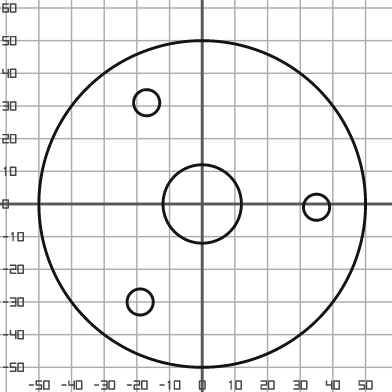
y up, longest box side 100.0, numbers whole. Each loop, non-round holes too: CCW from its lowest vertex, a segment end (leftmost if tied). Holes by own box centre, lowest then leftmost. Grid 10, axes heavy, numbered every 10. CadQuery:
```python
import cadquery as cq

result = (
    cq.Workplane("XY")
    .moveTo(0.0, 0.0)
    .circle(50.0)
    .moveTo(-19.0, -30.0)
    .circle(4.0)
    .moveTo(35.0, -1.0)
    .circle(4.0)
    .moveTo(0.0, 0.0)
    .circle(12.0)
    .moveTo(-17.0, 31.0)
    .circle(4.0)
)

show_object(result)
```